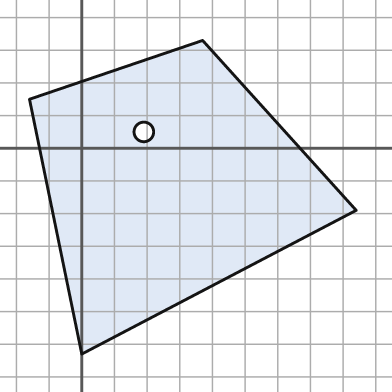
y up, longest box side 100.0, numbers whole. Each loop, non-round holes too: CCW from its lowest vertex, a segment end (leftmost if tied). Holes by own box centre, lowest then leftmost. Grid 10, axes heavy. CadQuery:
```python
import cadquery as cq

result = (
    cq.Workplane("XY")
    .moveTo(0.0, -63.0)
    .lineTo(84.0, -19.0)
    .lineTo(37.0, 33.0)
    .lineTo(-16.0, 15.0)
    .close()
    .moveTo(19.0, 5.0)
    .circle(3.0)
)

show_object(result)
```